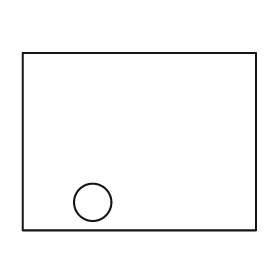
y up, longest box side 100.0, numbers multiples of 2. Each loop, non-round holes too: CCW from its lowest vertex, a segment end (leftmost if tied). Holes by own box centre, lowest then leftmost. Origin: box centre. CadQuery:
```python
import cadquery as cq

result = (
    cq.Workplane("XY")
    .moveTo(-50.0, -38.0)
    .lineTo(50.0, -38.0)
    .lineTo(50.0, 38.0)
    .lineTo(-50.0, 38.0)
    .close()
    .moveTo(-20.0, -26.0)
    .circle(8.0)
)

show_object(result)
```